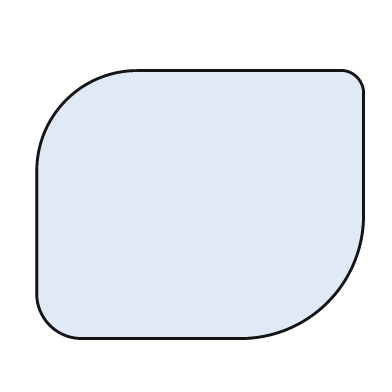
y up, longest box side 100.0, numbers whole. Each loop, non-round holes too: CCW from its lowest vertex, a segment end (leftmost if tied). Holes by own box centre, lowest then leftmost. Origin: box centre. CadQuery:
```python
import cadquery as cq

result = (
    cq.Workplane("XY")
    .moveTo(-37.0, -41.0)
    .lineTo(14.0, -41.0)
    .threePointArc((39.0, -30.0), (50.0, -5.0))
    .lineTo(50.0, 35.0)
    .threePointArc((48.0, 39.0), (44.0, 41.0))
    .lineTo(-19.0, 41.0)
    .threePointArc((-41.0, 32.0), (-50.0, 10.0))
    .lineTo(-50.0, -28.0)
    .threePointArc((-46.0, -37.0), (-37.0, -41.0))
    .close()
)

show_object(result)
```